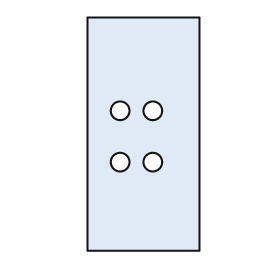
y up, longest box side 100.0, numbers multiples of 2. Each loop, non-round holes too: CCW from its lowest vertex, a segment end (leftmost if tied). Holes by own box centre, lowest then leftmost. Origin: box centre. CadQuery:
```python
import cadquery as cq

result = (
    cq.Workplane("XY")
    .moveTo(-24.0, -50.0)
    .lineTo(24.0, -50.0)
    .lineTo(24.0, 50.0)
    .lineTo(-24.0, 50.0)
    .close()
    .moveTo(-10.0, -12.0)
    .circle(4.0)
    .moveTo(4.0, -12.0)
    .circle(4.0)
    .moveTo(-10.0, 10.0)
    .circle(4.0)
    .moveTo(4.0, 10.0)
    .circle(4.0)
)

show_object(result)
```